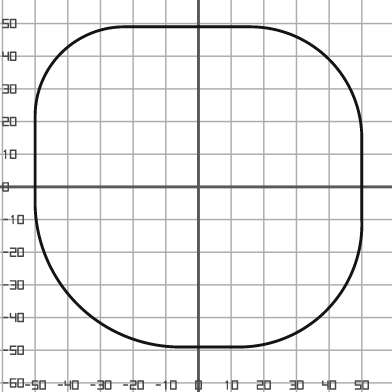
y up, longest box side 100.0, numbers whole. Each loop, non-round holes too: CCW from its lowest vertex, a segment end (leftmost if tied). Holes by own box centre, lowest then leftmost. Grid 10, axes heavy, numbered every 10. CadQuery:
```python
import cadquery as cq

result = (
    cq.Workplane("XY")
    .moveTo(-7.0, -49.0)
    .lineTo(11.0, -49.0)
    .threePointArc((39.0, -38.0), (50.0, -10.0))
    .lineTo(50.0, 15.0)
    .threePointArc((40.0, 39.0), (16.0, 49.0))
    .lineTo(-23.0, 49.0)
    .threePointArc((-42.0, 41.0), (-50.0, 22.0))
    .lineTo(-50.0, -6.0)
    .threePointArc((-37.0, -36.0), (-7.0, -49.0))
    .close()
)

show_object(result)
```